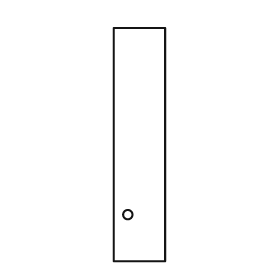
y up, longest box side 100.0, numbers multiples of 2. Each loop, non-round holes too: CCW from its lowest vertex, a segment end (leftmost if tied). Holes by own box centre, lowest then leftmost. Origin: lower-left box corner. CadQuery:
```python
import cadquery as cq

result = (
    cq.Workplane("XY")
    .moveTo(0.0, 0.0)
    .lineTo(22.0, 0.0)
    .lineTo(22.0, 100.0)
    .lineTo(0.0, 100.0)
    .close()
    .moveTo(6.0, 20.0)
    .circle(2.0)
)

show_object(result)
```